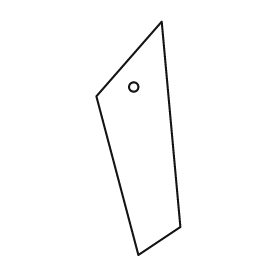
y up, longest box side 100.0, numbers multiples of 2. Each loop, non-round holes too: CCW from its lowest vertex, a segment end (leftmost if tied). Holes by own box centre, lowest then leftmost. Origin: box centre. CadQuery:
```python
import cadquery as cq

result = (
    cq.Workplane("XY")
    .moveTo(0.0, -50.0)
    .lineTo(18.0, -38.0)
    .lineTo(10.0, 50.0)
    .lineTo(-18.0, 18.0)
    .close()
    .moveTo(-2.0, 22.0)
    .circle(2.0)
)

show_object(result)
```